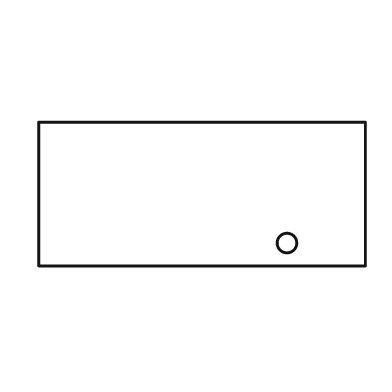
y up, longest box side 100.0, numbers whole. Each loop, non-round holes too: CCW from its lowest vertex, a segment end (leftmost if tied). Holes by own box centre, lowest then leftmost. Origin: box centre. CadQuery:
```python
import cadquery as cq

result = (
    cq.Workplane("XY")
    .moveTo(-50.0, -22.0)
    .lineTo(50.0, -22.0)
    .lineTo(50.0, 22.0)
    .lineTo(-50.0, 22.0)
    .close()
    .moveTo(26.0, -15.0)
    .circle(3.0)
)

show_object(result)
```